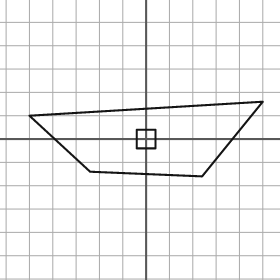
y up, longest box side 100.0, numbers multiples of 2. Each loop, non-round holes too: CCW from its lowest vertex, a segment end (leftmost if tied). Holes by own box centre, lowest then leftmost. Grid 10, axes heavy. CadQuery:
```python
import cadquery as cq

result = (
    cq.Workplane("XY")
    .moveTo(24.0, -16.0)
    .lineTo(50.0, 16.0)
    .lineTo(-50.0, 10.0)
    .lineTo(-24.0, -14.0)
    .close()
    .moveTo(-4.0, -4.0)
    .lineTo(4.0, -4.0)
    .lineTo(4.0, 4.0)
    .lineTo(-4.0, 4.0)
    .close()
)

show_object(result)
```